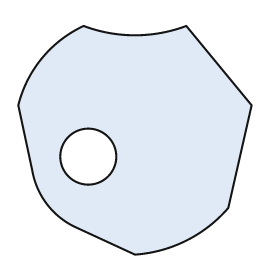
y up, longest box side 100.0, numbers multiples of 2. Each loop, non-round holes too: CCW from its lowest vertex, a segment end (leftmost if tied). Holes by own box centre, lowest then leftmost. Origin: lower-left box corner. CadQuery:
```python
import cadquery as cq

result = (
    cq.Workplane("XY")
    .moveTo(50.0, 0.0)
    .threePointArc((72.0, 6.0), (90.0, 20.0))
    .lineTo(100.0, 64.0)
    .lineTo(72.0, 98.0)
    .threePointArc((50.0, 94.0), (28.0, 98.0))
    .threePointArc((10.0, 84.0), (0.0, 64.0))
    .lineTo(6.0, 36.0)
    .threePointArc((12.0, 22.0), (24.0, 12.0))
    .close()
    .moveTo(30.0, 42.0)
    .circle(12.0)
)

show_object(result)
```